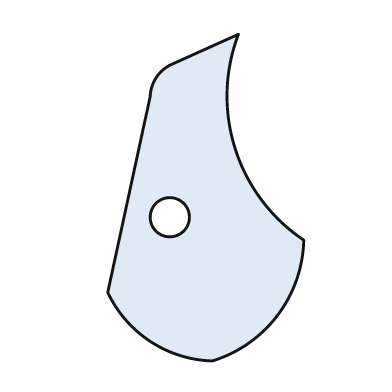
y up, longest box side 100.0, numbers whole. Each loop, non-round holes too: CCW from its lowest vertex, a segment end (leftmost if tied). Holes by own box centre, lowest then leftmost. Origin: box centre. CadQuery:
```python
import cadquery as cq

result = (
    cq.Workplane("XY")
    .moveTo(2.0, -50.0)
    .threePointArc((22.0, -36.0), (30.0, -13.0))
    .threePointArc((9.0, 15.0), (10.0, 50.0))
    .lineTo(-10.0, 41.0)
    .threePointArc((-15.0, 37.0), (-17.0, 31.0))
    .lineTo(-30.0, -29.0)
    .threePointArc((-17.0, -44.0), (2.0, -50.0))
    .close()
    .moveTo(-11.0, -6.0)
    .circle(6.0)
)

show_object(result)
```